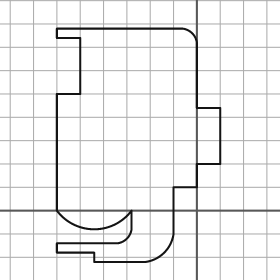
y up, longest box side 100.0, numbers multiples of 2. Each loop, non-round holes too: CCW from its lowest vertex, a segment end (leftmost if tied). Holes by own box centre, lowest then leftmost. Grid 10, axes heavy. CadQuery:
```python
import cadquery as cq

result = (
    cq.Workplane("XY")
    .moveTo(-44.0, -22.0)
    .lineTo(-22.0, -22.0)
    .threePointArc((-14.0, -18.0), (-10.0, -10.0))
    .lineTo(-10.0, 10.0)
    .lineTo(0.0, 10.0)
    .lineTo(0.0, 20.0)
    .lineTo(10.0, 20.0)
    .lineTo(10.0, 44.0)
    .lineTo(0.0, 44.0)
    .lineTo(0.0, 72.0)
    .threePointArc((-2.0, 76.0), (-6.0, 78.0))
    .lineTo(-60.0, 78.0)
    .lineTo(-60.0, 74.0)
    .lineTo(-50.0, 74.0)
    .lineTo(-50.0, 50.0)
    .lineTo(-60.0, 50.0)
    .lineTo(-60.0, 0.0)
    .threePointArc((-44.0, -8.0), (-28.0, 0.0))
    .lineTo(-28.0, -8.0)
    .threePointArc((-30.0, -12.0), (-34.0, -14.0))
    .lineTo(-60.0, -14.0)
    .lineTo(-60.0, -18.0)
    .lineTo(-44.0, -18.0)
    .close()
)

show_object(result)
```